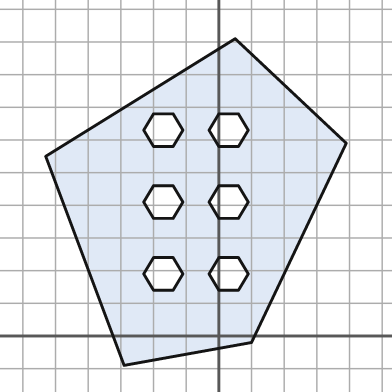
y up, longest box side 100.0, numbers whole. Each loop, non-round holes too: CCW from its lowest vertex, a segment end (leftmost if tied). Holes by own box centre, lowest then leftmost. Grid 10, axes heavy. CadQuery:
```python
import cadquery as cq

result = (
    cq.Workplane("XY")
    .moveTo(-29.0, -9.0)
    .lineTo(10.0, -2.0)
    .lineTo(39.0, 59.0)
    .lineTo(5.0, 91.0)
    .lineTo(-53.0, 55.0)
    .close()
    .moveTo(-20.0, 14.0)
    .lineTo(-14.0, 14.0)
    .lineTo(-11.0, 19.0)
    .lineTo(-14.0, 24.0)
    .lineTo(-20.0, 24.0)
    .lineTo(-23.0, 19.0)
    .close()
    .moveTo(0.0, 14.0)
    .lineTo(6.0, 14.0)
    .lineTo(9.0, 19.0)
    .lineTo(6.0, 24.0)
    .lineTo(0.0, 24.0)
    .lineTo(-3.0, 19.0)
    .close()
    .moveTo(-20.0, 36.0)
    .lineTo(-14.0, 36.0)
    .lineTo(-11.0, 41.0)
    .lineTo(-14.0, 46.0)
    .lineTo(-20.0, 46.0)
    .lineTo(-23.0, 41.0)
    .close()
    .moveTo(0.0, 36.0)
    .lineTo(6.0, 36.0)
    .lineTo(9.0, 41.0)
    .lineTo(6.0, 46.0)
    .lineTo(0.0, 46.0)
    .lineTo(-3.0, 41.0)
    .close()
    .moveTo(-20.0, 58.0)
    .lineTo(-14.0, 58.0)
    .lineTo(-11.0, 63.0)
    .lineTo(-14.0, 68.0)
    .lineTo(-20.0, 68.0)
    .lineTo(-23.0, 63.0)
    .close()
    .moveTo(0.0, 58.0)
    .lineTo(6.0, 58.0)
    .lineTo(9.0, 63.0)
    .lineTo(6.0, 68.0)
    .lineTo(0.0, 68.0)
    .lineTo(-3.0, 63.0)
    .close()
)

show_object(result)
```